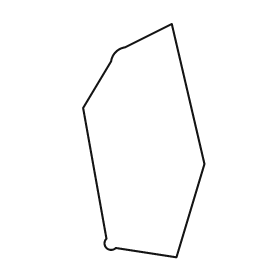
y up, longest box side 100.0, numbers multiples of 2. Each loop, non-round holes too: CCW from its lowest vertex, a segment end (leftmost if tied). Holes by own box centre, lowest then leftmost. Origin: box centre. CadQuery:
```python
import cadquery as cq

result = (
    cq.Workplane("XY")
    .moveTo(14.0, -50.0)
    .lineTo(26.0, -10.0)
    .lineTo(12.0, 50.0)
    .lineTo(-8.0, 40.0)
    .threePointArc((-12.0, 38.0), (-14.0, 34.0))
    .lineTo(-26.0, 14.0)
    .lineTo(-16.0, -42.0)
    .threePointArc((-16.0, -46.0), (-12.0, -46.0))
    .close()
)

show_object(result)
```